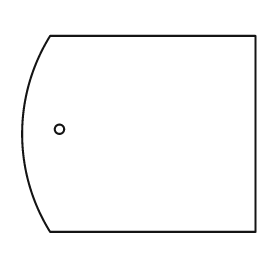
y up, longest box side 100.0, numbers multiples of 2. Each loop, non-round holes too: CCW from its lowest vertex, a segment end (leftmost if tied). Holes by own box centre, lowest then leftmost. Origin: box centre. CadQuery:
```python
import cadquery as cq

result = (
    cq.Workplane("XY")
    .moveTo(-38.0, -42.0)
    .lineTo(50.0, -42.0)
    .lineTo(50.0, 42.0)
    .lineTo(-38.0, 42.0)
    .threePointArc((-50.0, 0.0), (-38.0, -42.0))
    .close()
    .moveTo(-34.0, 2.0)
    .circle(2.0)
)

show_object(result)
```